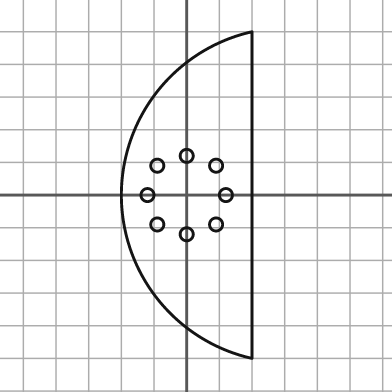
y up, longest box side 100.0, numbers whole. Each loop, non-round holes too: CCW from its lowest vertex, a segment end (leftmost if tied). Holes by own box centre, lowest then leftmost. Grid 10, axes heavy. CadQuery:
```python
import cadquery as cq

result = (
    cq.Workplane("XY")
    .moveTo(20.0, -50.0)
    .lineTo(20.0, 50.0)
    .threePointArc((-20.0, 0.0), (20.0, -50.0))
    .close()
    .moveTo(0.0, -12.0)
    .circle(2.0)
    .moveTo(-9.0, -9.0)
    .circle(2.0)
    .moveTo(9.0, -9.0)
    .circle(2.0)
    .moveTo(-12.0, 0.0)
    .circle(2.0)
    .moveTo(12.0, 0.0)
    .circle(2.0)
    .moveTo(-9.0, 9.0)
    .circle(2.0)
    .moveTo(9.0, 9.0)
    .circle(2.0)
    .moveTo(0.0, 12.0)
    .circle(2.0)
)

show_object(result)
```